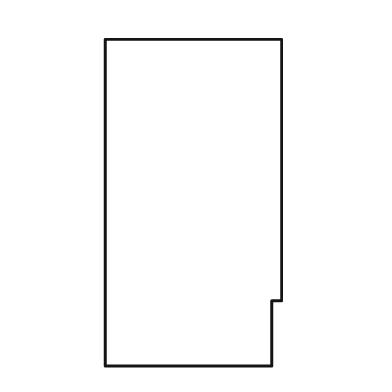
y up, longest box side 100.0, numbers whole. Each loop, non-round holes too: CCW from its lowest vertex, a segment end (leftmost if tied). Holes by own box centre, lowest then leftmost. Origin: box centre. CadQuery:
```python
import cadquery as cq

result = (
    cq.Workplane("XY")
    .moveTo(-27.0, -50.0)
    .lineTo(24.0, -50.0)
    .lineTo(24.0, -30.0)
    .lineTo(27.0, -30.0)
    .lineTo(27.0, 50.0)
    .lineTo(-27.0, 50.0)
    .close()
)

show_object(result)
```